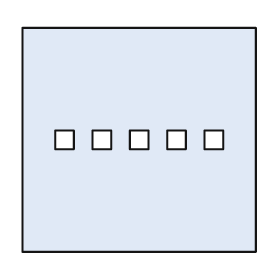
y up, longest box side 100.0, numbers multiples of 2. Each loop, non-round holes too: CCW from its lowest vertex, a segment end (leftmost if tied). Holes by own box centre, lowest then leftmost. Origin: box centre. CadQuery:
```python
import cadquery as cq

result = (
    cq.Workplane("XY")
    .moveTo(-50.0, -48.0)
    .lineTo(50.0, -48.0)
    .lineTo(50.0, 48.0)
    .lineTo(-50.0, 48.0)
    .close()
    .moveTo(-36.0, -4.0)
    .lineTo(-28.0, -4.0)
    .lineTo(-28.0, 4.0)
    .lineTo(-36.0, 4.0)
    .close()
    .moveTo(-20.0, -4.0)
    .lineTo(-12.0, -4.0)
    .lineTo(-12.0, 4.0)
    .lineTo(-20.0, 4.0)
    .close()
    .moveTo(-4.0, -4.0)
    .lineTo(4.0, -4.0)
    .lineTo(4.0, 4.0)
    .lineTo(-4.0, 4.0)
    .close()
    .moveTo(12.0, -4.0)
    .lineTo(20.0, -4.0)
    .lineTo(20.0, 4.0)
    .lineTo(12.0, 4.0)
    .close()
    .moveTo(28.0, -4.0)
    .lineTo(36.0, -4.0)
    .lineTo(36.0, 4.0)
    .lineTo(28.0, 4.0)
    .close()
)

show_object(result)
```